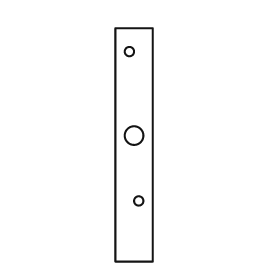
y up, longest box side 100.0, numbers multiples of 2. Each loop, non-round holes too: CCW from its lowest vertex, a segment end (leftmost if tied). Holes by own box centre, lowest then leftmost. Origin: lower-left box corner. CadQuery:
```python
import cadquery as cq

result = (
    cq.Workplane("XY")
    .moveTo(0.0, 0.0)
    .lineTo(16.0, 0.0)
    .lineTo(16.0, 100.0)
    .lineTo(0.0, 100.0)
    .close()
    .moveTo(10.0, 26.0)
    .circle(2.0)
    .moveTo(8.0, 54.0)
    .circle(4.0)
    .moveTo(6.0, 90.0)
    .circle(2.0)
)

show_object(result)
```